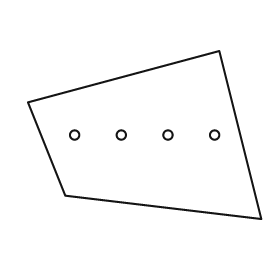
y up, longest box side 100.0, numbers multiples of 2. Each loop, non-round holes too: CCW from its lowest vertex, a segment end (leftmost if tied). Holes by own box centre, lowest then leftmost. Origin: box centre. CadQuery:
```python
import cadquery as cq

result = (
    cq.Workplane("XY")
    .moveTo(50.0, -36.0)
    .lineTo(32.0, 36.0)
    .lineTo(-50.0, 14.0)
    .lineTo(-34.0, -26.0)
    .close()
    .moveTo(-30.0, 0.0)
    .circle(2.0)
    .moveTo(-10.0, 0.0)
    .circle(2.0)
    .moveTo(10.0, 0.0)
    .circle(2.0)
    .moveTo(30.0, 0.0)
    .circle(2.0)
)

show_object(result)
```